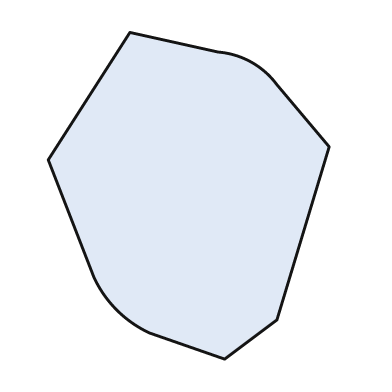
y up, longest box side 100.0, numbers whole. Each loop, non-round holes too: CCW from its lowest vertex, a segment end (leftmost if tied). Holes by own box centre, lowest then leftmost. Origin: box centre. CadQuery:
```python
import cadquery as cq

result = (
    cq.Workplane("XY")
    .moveTo(11.0, -50.0)
    .lineTo(27.0, -38.0)
    .lineTo(43.0, 15.0)
    .lineTo(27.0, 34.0)
    .threePointArc((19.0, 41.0), (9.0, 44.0))
    .lineTo(-18.0, 50.0)
    .lineTo(-43.0, 11.0)
    .lineTo(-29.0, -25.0)
    .threePointArc((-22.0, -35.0), (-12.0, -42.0))
    .close()
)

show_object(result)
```